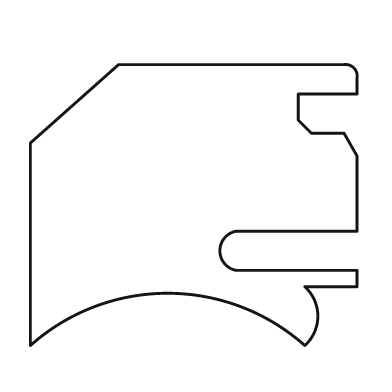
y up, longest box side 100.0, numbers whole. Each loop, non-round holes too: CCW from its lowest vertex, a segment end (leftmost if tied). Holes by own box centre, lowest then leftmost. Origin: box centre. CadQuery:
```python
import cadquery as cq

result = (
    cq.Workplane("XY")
    .moveTo(-50.0, -43.0)
    .threePointArc((-8.0, -27.0), (34.0, -43.0))
    .threePointArc((38.0, -34.0), (34.0, -25.0))
    .lineTo(50.0, -25.0)
    .lineTo(50.0, -20.0)
    .lineTo(13.0, -20.0)
    .threePointArc((8.0, -14.0), (13.0, -8.0))
    .lineTo(50.0, -8.0)
    .lineTo(50.0, 15.0)
    .lineTo(46.0, 22.0)
    .lineTo(36.0, 22.0)
    .lineTo(32.0, 26.0)
    .lineTo(32.0, 34.0)
    .lineTo(50.0, 34.0)
    .lineTo(50.0, 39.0)
    .threePointArc((49.0, 42.0), (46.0, 43.0))
    .lineTo(-23.0, 43.0)
    .lineTo(-50.0, 19.0)
    .close()
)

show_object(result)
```